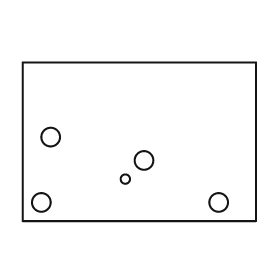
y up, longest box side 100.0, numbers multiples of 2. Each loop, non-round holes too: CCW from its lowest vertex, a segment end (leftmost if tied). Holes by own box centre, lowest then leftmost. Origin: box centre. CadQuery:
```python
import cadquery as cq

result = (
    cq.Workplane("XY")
    .moveTo(-50.0, -34.0)
    .lineTo(50.0, -34.0)
    .lineTo(50.0, 34.0)
    .lineTo(-50.0, 34.0)
    .close()
    .moveTo(-42.0, -26.0)
    .circle(4.0)
    .moveTo(34.0, -26.0)
    .circle(4.0)
    .moveTo(-6.0, -16.0)
    .circle(2.0)
    .moveTo(2.0, -8.0)
    .circle(4.0)
    .moveTo(-38.0, 2.0)
    .circle(4.0)
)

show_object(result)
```